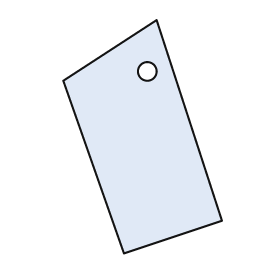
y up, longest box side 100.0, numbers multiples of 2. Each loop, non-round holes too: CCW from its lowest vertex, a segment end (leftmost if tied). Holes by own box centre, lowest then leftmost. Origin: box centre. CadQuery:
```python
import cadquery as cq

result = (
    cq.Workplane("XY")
    .moveTo(-8.0, -50.0)
    .lineTo(34.0, -36.0)
    .lineTo(6.0, 50.0)
    .lineTo(-34.0, 24.0)
    .close()
    .moveTo(2.0, 28.0)
    .circle(4.0)
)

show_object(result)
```